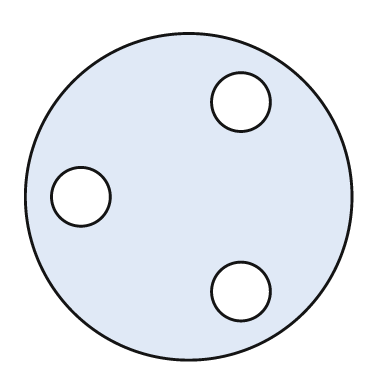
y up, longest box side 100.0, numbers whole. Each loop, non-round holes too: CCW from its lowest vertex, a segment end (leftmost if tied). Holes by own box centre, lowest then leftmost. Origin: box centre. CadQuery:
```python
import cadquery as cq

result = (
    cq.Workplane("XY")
    .moveTo(0.0, 0.0)
    .circle(50.0)
    .moveTo(16.0, -29.0)
    .circle(9.0)
    .moveTo(-33.0, 0.0)
    .circle(9.0)
    .moveTo(16.0, 29.0)
    .circle(9.0)
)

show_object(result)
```